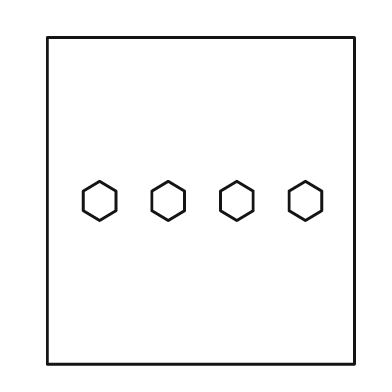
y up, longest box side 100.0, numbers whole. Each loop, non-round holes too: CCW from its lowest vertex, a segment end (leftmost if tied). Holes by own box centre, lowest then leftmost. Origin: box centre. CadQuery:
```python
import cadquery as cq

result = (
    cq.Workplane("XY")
    .moveTo(-47.0, -50.0)
    .lineTo(47.0, -50.0)
    .lineTo(47.0, 50.0)
    .lineTo(-47.0, 50.0)
    .close()
    .moveTo(-31.0, -6.0)
    .lineTo(-26.0, -3.0)
    .lineTo(-26.0, 3.0)
    .lineTo(-31.0, 6.0)
    .lineTo(-36.0, 3.0)
    .lineTo(-36.0, -3.0)
    .close()
    .moveTo(-10.0, -6.0)
    .lineTo(-5.0, -3.0)
    .lineTo(-5.0, 3.0)
    .lineTo(-10.0, 6.0)
    .lineTo(-15.0, 3.0)
    .lineTo(-15.0, -3.0)
    .close()
    .moveTo(11.0, -6.0)
    .lineTo(16.0, -3.0)
    .lineTo(16.0, 3.0)
    .lineTo(11.0, 6.0)
    .lineTo(6.0, 3.0)
    .lineTo(6.0, -3.0)
    .close()
    .moveTo(32.0, -6.0)
    .lineTo(37.0, -3.0)
    .lineTo(37.0, 3.0)
    .lineTo(32.0, 6.0)
    .lineTo(27.0, 3.0)
    .lineTo(27.0, -3.0)
    .close()
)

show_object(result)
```